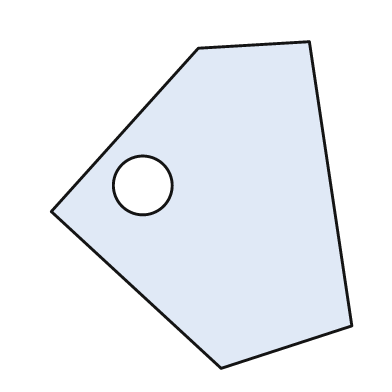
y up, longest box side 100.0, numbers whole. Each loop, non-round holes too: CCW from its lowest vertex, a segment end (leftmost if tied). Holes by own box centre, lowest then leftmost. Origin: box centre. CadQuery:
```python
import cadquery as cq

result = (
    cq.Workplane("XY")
    .moveTo(6.0, -50.0)
    .lineTo(46.0, -37.0)
    .lineTo(33.0, 50.0)
    .lineTo(-1.0, 48.0)
    .lineTo(-46.0, -2.0)
    .close()
    .moveTo(-18.0, 6.0)
    .circle(9.0)
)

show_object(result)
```